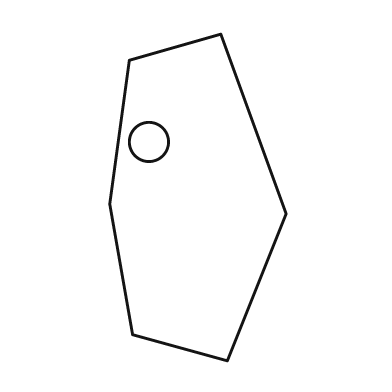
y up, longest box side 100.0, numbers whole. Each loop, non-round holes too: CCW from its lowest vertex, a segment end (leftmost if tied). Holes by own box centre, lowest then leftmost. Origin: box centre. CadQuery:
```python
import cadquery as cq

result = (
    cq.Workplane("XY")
    .moveTo(9.0, -50.0)
    .lineTo(27.0, -5.0)
    .lineTo(7.0, 50.0)
    .lineTo(-21.0, 42.0)
    .lineTo(-27.0, -2.0)
    .lineTo(-20.0, -42.0)
    .close()
    .moveTo(-15.0, 17.0)
    .circle(6.0)
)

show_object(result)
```